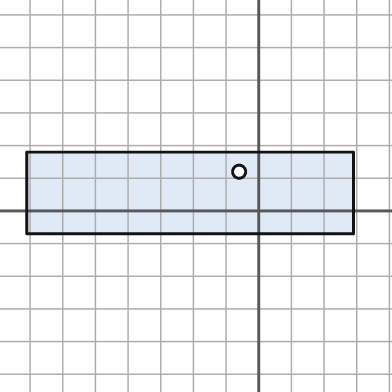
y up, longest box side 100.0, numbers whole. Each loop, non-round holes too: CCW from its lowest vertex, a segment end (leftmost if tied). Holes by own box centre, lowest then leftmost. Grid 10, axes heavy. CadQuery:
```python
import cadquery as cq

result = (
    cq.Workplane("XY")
    .moveTo(-71.0, -7.0)
    .lineTo(29.0, -7.0)
    .lineTo(29.0, 18.0)
    .lineTo(-71.0, 18.0)
    .close()
    .moveTo(-6.0, 12.0)
    .circle(2.0)
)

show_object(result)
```